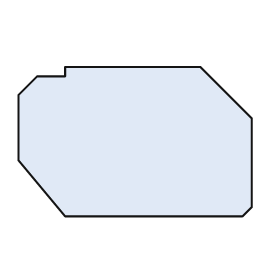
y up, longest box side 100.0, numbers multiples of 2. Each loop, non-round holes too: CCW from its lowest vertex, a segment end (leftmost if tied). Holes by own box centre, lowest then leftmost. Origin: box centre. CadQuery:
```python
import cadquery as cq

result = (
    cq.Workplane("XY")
    .moveTo(-30.0, -32.0)
    .lineTo(46.0, -32.0)
    .lineTo(50.0, -28.0)
    .lineTo(50.0, 10.0)
    .lineTo(28.0, 32.0)
    .lineTo(-30.0, 32.0)
    .lineTo(-30.0, 28.0)
    .lineTo(-42.0, 28.0)
    .lineTo(-50.0, 20.0)
    .lineTo(-50.0, -8.0)
    .close()
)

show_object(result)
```